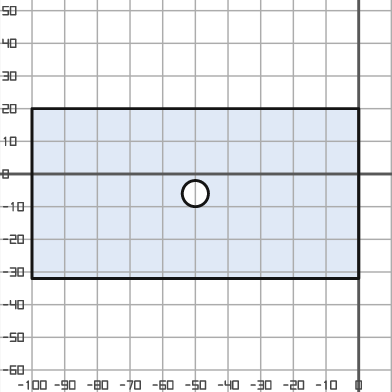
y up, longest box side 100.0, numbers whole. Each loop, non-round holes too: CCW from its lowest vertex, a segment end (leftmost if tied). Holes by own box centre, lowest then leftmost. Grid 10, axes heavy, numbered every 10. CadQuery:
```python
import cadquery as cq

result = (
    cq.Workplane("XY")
    .moveTo(-100.0, -32.0)
    .lineTo(0.0, -32.0)
    .lineTo(0.0, 20.0)
    .lineTo(-100.0, 20.0)
    .close()
    .moveTo(-50.0, -6.0)
    .circle(4.0)
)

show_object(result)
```